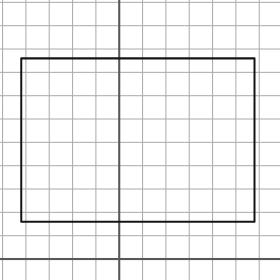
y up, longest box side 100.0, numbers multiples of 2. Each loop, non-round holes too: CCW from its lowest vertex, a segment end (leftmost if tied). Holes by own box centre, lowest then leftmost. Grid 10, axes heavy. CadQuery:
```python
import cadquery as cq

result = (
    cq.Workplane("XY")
    .moveTo(-42.0, 16.0)
    .lineTo(58.0, 16.0)
    .lineTo(58.0, 86.0)
    .lineTo(-42.0, 86.0)
    .close()
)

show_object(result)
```